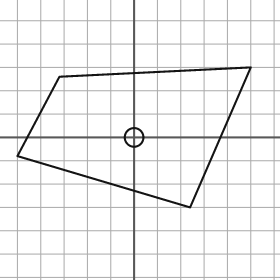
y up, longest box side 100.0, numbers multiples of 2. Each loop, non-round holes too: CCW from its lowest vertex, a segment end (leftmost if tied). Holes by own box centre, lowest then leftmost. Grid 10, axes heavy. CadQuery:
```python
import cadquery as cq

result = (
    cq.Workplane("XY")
    .moveTo(24.0, -30.0)
    .lineTo(50.0, 30.0)
    .lineTo(-32.0, 26.0)
    .lineTo(-50.0, -8.0)
    .close()
    .moveTo(0.0, 0.0)
    .circle(4.0)
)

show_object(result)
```